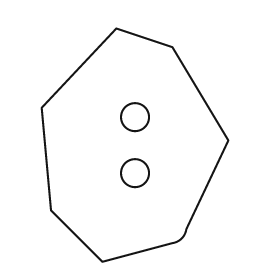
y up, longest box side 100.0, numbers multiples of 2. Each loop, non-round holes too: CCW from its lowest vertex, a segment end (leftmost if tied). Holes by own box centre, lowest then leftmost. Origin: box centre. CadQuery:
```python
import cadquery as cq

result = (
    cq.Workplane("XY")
    .moveTo(-14.0, -50.0)
    .lineTo(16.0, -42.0)
    .threePointArc((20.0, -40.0), (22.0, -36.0))
    .lineTo(40.0, 2.0)
    .lineTo(16.0, 42.0)
    .lineTo(-8.0, 50.0)
    .lineTo(-40.0, 16.0)
    .lineTo(-36.0, -28.0)
    .close()
    .moveTo(0.0, -12.0)
    .circle(6.0)
    .moveTo(0.0, 12.0)
    .circle(6.0)
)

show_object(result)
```